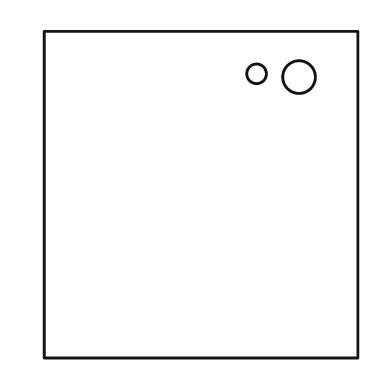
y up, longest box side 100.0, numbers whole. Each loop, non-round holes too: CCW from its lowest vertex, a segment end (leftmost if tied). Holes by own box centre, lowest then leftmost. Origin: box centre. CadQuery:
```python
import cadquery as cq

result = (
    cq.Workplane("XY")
    .moveTo(-48.0, -50.0)
    .lineTo(48.0, -50.0)
    .lineTo(48.0, 50.0)
    .lineTo(-48.0, 50.0)
    .close()
    .moveTo(30.0, 36.0)
    .circle(5.0)
    .moveTo(17.0, 37.0)
    .circle(3.0)
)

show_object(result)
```